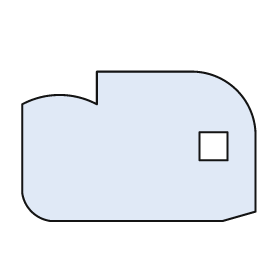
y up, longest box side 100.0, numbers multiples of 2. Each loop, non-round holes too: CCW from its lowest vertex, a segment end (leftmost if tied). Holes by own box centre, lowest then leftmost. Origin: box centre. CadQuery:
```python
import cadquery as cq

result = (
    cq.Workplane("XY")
    .moveTo(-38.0, -32.0)
    .lineTo(36.0, -32.0)
    .lineTo(50.0, -28.0)
    .lineTo(50.0, 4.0)
    .threePointArc((42.0, 24.0), (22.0, 32.0))
    .lineTo(-18.0, 32.0)
    .lineTo(-18.0, 18.0)
    .threePointArc((-34.0, 22.0), (-50.0, 18.0))
    .lineTo(-50.0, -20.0)
    .threePointArc((-46.0, -28.0), (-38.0, -32.0))
    .close()
    .moveTo(26.0, -6.0)
    .lineTo(38.0, -6.0)
    .lineTo(38.0, 6.0)
    .lineTo(26.0, 6.0)
    .close()
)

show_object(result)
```